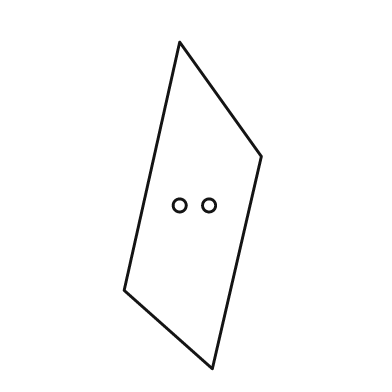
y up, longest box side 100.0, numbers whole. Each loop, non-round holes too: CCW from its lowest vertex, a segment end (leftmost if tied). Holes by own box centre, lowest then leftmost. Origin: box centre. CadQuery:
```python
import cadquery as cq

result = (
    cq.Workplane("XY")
    .moveTo(6.0, -50.0)
    .lineTo(21.0, 15.0)
    .lineTo(-4.0, 50.0)
    .lineTo(-21.0, -26.0)
    .close()
    .moveTo(-4.0, 0.0)
    .circle(2.0)
    .moveTo(5.0, 0.0)
    .circle(2.0)
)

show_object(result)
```